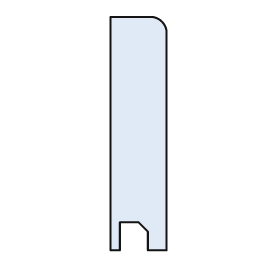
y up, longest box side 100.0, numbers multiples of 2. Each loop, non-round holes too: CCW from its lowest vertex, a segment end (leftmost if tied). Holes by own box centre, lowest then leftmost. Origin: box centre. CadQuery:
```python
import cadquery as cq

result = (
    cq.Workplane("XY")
    .moveTo(-12.0, -50.0)
    .lineTo(-8.0, -50.0)
    .lineTo(-8.0, -38.0)
    .lineTo(0.0, -38.0)
    .lineTo(4.0, -42.0)
    .lineTo(4.0, -50.0)
    .lineTo(12.0, -50.0)
    .lineTo(12.0, 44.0)
    .threePointArc((10.0, 48.0), (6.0, 50.0))
    .lineTo(-12.0, 50.0)
    .close()
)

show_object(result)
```